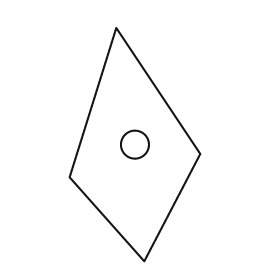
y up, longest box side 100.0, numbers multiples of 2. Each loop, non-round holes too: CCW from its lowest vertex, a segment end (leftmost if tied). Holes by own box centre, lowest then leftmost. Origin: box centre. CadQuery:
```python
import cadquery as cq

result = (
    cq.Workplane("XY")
    .moveTo(4.0, -50.0)
    .lineTo(28.0, -4.0)
    .lineTo(-8.0, 50.0)
    .lineTo(-28.0, -14.0)
    .close()
    .moveTo(0.0, 0.0)
    .circle(6.0)
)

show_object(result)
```